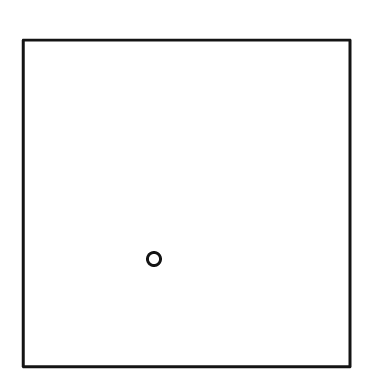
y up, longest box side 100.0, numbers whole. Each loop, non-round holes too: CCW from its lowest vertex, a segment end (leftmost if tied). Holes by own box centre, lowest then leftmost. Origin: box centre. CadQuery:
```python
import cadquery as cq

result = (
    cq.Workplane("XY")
    .moveTo(-50.0, -50.0)
    .lineTo(50.0, -50.0)
    .lineTo(50.0, 50.0)
    .lineTo(-50.0, 50.0)
    .close()
    .moveTo(-10.0, -17.0)
    .circle(2.0)
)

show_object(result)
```